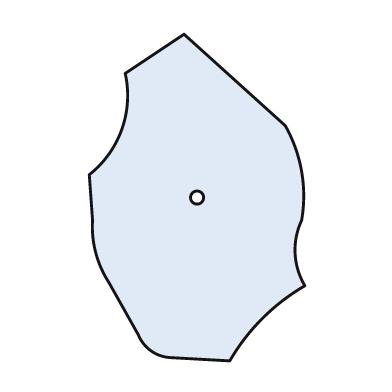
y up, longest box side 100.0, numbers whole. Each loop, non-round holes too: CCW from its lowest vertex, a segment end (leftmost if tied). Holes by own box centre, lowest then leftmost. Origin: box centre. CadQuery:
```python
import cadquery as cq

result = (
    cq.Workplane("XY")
    .moveTo(10.0, -50.0)
    .threePointArc((20.0, -37.0), (33.0, -27.0))
    .threePointArc((30.0, -17.0), (32.0, -7.0))
    .threePointArc((32.0, 8.0), (27.0, 22.0))
    .lineTo(-4.0, 50.0)
    .lineTo(-22.0, 38.0)
    .threePointArc((-23.0, 21.0), (-33.0, 7.0))
    .lineTo(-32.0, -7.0)
    .threePointArc((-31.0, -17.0), (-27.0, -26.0))
    .lineTo(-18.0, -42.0)
    .threePointArc((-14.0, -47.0), (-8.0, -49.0))
    .close()
    .moveTo(0.0, 0.0)
    .circle(2.0)
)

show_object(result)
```